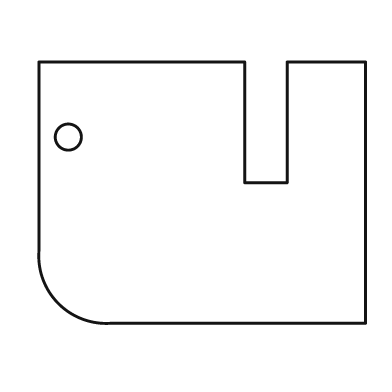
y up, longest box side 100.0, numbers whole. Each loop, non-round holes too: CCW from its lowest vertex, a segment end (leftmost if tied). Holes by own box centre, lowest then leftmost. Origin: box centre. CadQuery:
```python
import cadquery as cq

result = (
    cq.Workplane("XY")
    .moveTo(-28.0, -40.0)
    .lineTo(50.0, -40.0)
    .lineTo(50.0, 40.0)
    .lineTo(26.0, 40.0)
    .lineTo(26.0, 3.0)
    .lineTo(13.0, 3.0)
    .lineTo(13.0, 40.0)
    .lineTo(-50.0, 40.0)
    .lineTo(-50.0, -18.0)
    .threePointArc((-44.0, -34.0), (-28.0, -40.0))
    .close()
    .moveTo(-41.0, 17.0)
    .circle(4.0)
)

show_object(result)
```